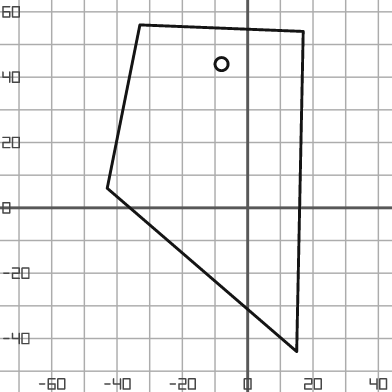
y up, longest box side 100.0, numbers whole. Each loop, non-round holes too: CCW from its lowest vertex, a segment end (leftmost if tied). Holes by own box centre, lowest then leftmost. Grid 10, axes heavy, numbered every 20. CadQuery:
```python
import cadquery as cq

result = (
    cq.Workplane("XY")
    .moveTo(15.0, -44.0)
    .lineTo(17.0, 54.0)
    .lineTo(-33.0, 56.0)
    .lineTo(-43.0, 6.0)
    .close()
    .moveTo(-8.0, 44.0)
    .circle(2.0)
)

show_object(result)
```